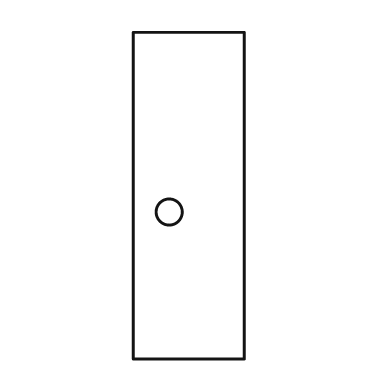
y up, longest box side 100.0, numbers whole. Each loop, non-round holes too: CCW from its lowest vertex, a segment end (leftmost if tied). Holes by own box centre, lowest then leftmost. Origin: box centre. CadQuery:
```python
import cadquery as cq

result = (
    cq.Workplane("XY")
    .moveTo(-17.0, -50.0)
    .lineTo(17.0, -50.0)
    .lineTo(17.0, 50.0)
    .lineTo(-17.0, 50.0)
    .close()
    .moveTo(-6.0, -5.0)
    .circle(4.0)
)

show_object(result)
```